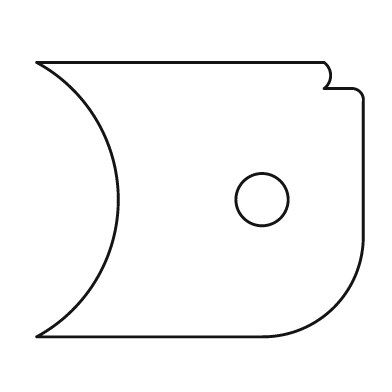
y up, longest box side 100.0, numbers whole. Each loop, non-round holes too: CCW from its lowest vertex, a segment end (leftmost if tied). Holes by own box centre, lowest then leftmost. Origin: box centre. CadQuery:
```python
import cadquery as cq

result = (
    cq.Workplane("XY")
    .moveTo(-50.0, -42.0)
    .lineTo(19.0, -42.0)
    .threePointArc((41.0, -33.0), (50.0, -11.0))
    .lineTo(50.0, 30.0)
    .threePointArc((49.0, 33.0), (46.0, 34.0))
    .lineTo(38.0, 34.0)
    .threePointArc((40.0, 38.0), (38.0, 42.0))
    .lineTo(-50.0, 42.0)
    .threePointArc((-25.0, 0.0), (-50.0, -42.0))
    .close()
    .moveTo(19.0, 0.0)
    .circle(8.0)
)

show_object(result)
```